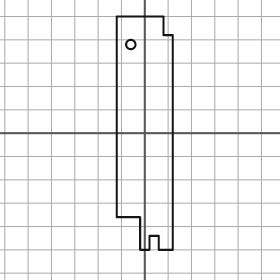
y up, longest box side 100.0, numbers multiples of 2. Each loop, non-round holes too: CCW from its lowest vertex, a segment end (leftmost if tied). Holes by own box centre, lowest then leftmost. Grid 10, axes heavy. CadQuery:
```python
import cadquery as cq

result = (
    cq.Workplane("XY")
    .moveTo(-2.0, -50.0)
    .lineTo(2.0, -50.0)
    .lineTo(2.0, -44.0)
    .lineTo(6.0, -44.0)
    .lineTo(6.0, -50.0)
    .lineTo(12.0, -50.0)
    .lineTo(12.0, 42.0)
    .lineTo(8.0, 42.0)
    .lineTo(8.0, 50.0)
    .lineTo(-12.0, 50.0)
    .lineTo(-12.0, -36.0)
    .lineTo(-2.0, -36.0)
    .close()
    .moveTo(-6.0, 38.0)
    .circle(2.0)
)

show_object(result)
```